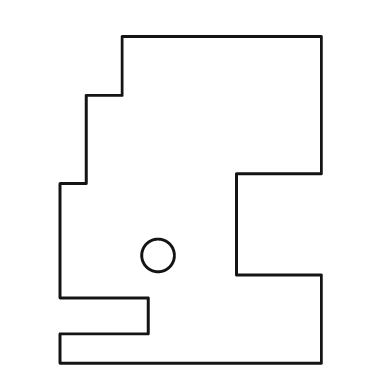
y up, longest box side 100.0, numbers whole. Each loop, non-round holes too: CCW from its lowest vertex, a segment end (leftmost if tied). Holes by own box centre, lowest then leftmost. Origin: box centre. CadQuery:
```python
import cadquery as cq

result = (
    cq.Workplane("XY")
    .moveTo(-40.0, -50.0)
    .lineTo(40.0, -50.0)
    .lineTo(40.0, -23.0)
    .lineTo(14.0, -23.0)
    .lineTo(14.0, 8.0)
    .lineTo(40.0, 8.0)
    .lineTo(40.0, 50.0)
    .lineTo(-21.0, 50.0)
    .lineTo(-21.0, 32.0)
    .lineTo(-32.0, 32.0)
    .lineTo(-32.0, 5.0)
    .lineTo(-40.0, 5.0)
    .lineTo(-40.0, -30.0)
    .lineTo(-13.0, -30.0)
    .lineTo(-13.0, -41.0)
    .lineTo(-40.0, -41.0)
    .close()
    .moveTo(-10.0, -17.0)
    .circle(5.0)
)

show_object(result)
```